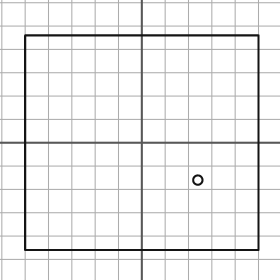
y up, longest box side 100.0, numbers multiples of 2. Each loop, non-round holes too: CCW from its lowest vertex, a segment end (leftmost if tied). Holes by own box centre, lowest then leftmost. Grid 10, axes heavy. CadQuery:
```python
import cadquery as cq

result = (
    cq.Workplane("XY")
    .moveTo(-50.0, -46.0)
    .lineTo(50.0, -46.0)
    .lineTo(50.0, 46.0)
    .lineTo(-50.0, 46.0)
    .close()
    .moveTo(24.0, -16.0)
    .circle(2.0)
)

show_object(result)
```